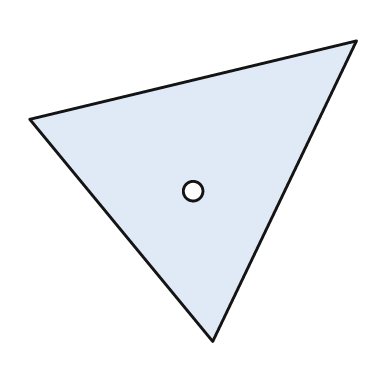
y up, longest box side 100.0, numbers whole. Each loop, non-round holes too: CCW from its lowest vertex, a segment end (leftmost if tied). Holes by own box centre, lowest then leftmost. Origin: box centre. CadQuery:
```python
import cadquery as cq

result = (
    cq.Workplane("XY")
    .moveTo(6.0, -46.0)
    .lineTo(50.0, 46.0)
    .lineTo(-50.0, 22.0)
    .close()
    .moveTo(0.0, 0.0)
    .circle(3.0)
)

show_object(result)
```